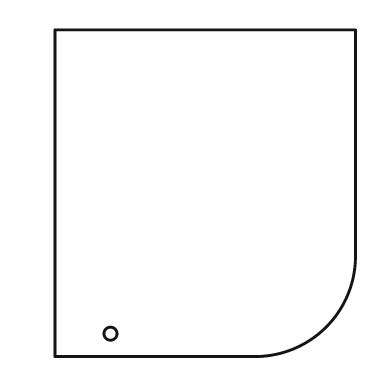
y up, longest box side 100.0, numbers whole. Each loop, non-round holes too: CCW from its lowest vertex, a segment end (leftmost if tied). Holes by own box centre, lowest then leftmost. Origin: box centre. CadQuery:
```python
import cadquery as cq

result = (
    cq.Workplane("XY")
    .moveTo(-46.0, -50.0)
    .lineTo(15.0, -50.0)
    .threePointArc((37.0, -41.0), (46.0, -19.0))
    .lineTo(46.0, 50.0)
    .lineTo(-46.0, 50.0)
    .close()
    .moveTo(-29.0, -43.0)
    .circle(2.0)
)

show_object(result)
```